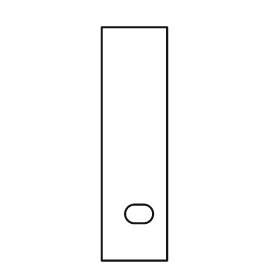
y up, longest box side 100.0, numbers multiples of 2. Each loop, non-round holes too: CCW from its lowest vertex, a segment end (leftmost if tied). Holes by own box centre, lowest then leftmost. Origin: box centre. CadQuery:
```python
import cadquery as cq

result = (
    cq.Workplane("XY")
    .moveTo(-14.0, -50.0)
    .lineTo(14.0, -50.0)
    .lineTo(14.0, 50.0)
    .lineTo(-14.0, 50.0)
    .close()
    .moveTo(0.0, -34.0)
    .lineTo(4.0, -34.0)
    .threePointArc((8.0, -30.0), (4.0, -26.0))
    .lineTo(0.0, -26.0)
    .threePointArc((-4.0, -30.0), (0.0, -34.0))
    .close()
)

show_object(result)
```